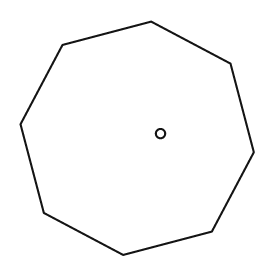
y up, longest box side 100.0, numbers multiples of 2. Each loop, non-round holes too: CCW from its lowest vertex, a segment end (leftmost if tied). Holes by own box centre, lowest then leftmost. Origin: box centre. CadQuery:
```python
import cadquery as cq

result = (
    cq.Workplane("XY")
    .moveTo(-6.0, -50.0)
    .lineTo(32.0, -40.0)
    .lineTo(50.0, -6.0)
    .lineTo(40.0, 32.0)
    .lineTo(6.0, 50.0)
    .lineTo(-32.0, 40.0)
    .lineTo(-50.0, 6.0)
    .lineTo(-40.0, -32.0)
    .close()
    .moveTo(10.0, 2.0)
    .circle(2.0)
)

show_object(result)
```